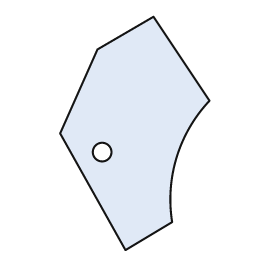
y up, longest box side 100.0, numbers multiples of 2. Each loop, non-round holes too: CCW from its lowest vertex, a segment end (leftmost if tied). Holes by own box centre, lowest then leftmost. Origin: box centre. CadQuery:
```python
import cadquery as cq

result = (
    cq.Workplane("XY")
    .moveTo(-4.0, -50.0)
    .lineTo(16.0, -38.0)
    .threePointArc((18.0, -10.0), (32.0, 14.0))
    .lineTo(8.0, 50.0)
    .lineTo(-16.0, 36.0)
    .lineTo(-32.0, 0.0)
    .close()
    .moveTo(-14.0, -8.0)
    .circle(4.0)
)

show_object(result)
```